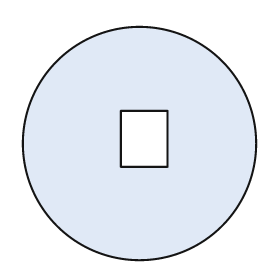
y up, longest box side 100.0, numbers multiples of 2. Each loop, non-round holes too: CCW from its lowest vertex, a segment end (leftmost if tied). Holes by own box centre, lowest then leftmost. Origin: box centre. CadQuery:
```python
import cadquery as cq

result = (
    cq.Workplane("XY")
    .moveTo(0.0, 0.0)
    .circle(50.0)
    .moveTo(-8.0, -10.0)
    .lineTo(12.0, -10.0)
    .lineTo(12.0, 14.0)
    .lineTo(-8.0, 14.0)
    .close()
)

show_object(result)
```